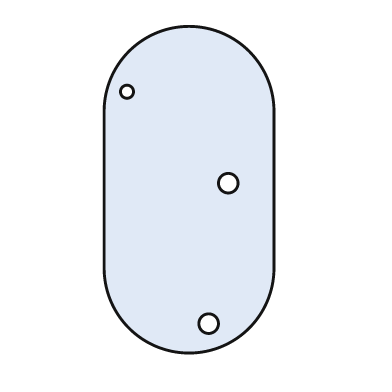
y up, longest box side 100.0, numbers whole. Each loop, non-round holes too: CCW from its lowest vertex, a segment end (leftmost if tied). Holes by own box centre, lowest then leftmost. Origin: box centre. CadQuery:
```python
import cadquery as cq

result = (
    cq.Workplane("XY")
    .moveTo(-26.0, -24.0)
    .threePointArc((0.0, -50.0), (26.0, -24.0))
    .lineTo(26.0, 24.0)
    .threePointArc((0.0, 50.0), (-26.0, 24.0))
    .close()
    .moveTo(6.0, -41.0)
    .circle(3.0)
    .moveTo(12.0, 2.0)
    .circle(3.0)
    .moveTo(-19.0, 30.0)
    .circle(2.0)
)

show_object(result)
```